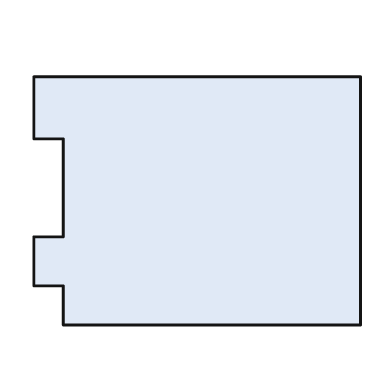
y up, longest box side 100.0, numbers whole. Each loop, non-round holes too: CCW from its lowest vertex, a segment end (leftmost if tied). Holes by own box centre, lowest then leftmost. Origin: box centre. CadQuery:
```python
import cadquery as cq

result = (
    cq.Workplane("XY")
    .moveTo(-41.0, -38.0)
    .lineTo(50.0, -38.0)
    .lineTo(50.0, 38.0)
    .lineTo(-50.0, 38.0)
    .lineTo(-50.0, 19.0)
    .lineTo(-41.0, 19.0)
    .lineTo(-41.0, -11.0)
    .lineTo(-50.0, -11.0)
    .lineTo(-50.0, -26.0)
    .lineTo(-41.0, -26.0)
    .close()
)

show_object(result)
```